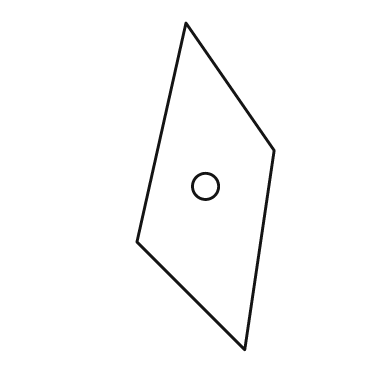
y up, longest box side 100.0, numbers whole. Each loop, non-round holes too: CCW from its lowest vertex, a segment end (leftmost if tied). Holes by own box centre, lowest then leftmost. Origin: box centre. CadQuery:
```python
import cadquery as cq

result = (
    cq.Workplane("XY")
    .moveTo(12.0, -50.0)
    .lineTo(21.0, 11.0)
    .lineTo(-6.0, 50.0)
    .lineTo(-21.0, -17.0)
    .close()
    .moveTo(0.0, 0.0)
    .circle(4.0)
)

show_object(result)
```